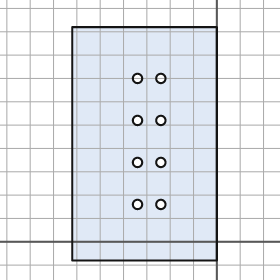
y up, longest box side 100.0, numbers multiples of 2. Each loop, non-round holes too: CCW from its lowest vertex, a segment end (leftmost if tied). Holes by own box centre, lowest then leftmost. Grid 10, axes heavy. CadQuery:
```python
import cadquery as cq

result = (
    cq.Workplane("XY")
    .moveTo(-62.0, -8.0)
    .lineTo(0.0, -8.0)
    .lineTo(0.0, 92.0)
    .lineTo(-62.0, 92.0)
    .close()
    .moveTo(-34.0, 16.0)
    .circle(2.0)
    .moveTo(-24.0, 16.0)
    .circle(2.0)
    .moveTo(-34.0, 34.0)
    .circle(2.0)
    .moveTo(-24.0, 34.0)
    .circle(2.0)
    .moveTo(-34.0, 52.0)
    .circle(2.0)
    .moveTo(-24.0, 52.0)
    .circle(2.0)
    .moveTo(-34.0, 70.0)
    .circle(2.0)
    .moveTo(-24.0, 70.0)
    .circle(2.0)
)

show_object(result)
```